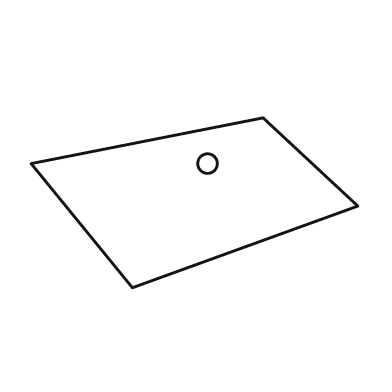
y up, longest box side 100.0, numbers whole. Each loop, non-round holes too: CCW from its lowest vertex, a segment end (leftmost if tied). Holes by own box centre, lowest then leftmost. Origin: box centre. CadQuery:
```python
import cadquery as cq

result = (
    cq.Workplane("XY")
    .moveTo(-19.0, -26.0)
    .lineTo(50.0, -1.0)
    .lineTo(21.0, 26.0)
    .lineTo(-50.0, 12.0)
    .close()
    .moveTo(4.0, 12.0)
    .circle(3.0)
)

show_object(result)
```